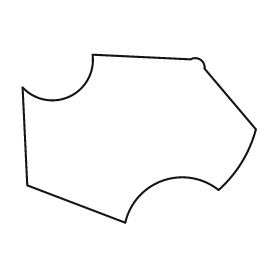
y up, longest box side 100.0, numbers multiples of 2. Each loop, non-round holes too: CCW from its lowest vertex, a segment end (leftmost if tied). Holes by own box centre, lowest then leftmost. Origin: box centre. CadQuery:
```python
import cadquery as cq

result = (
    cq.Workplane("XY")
    .moveTo(-6.0, -36.0)
    .threePointArc((10.0, -18.0), (34.0, -22.0))
    .threePointArc((44.0, -10.0), (50.0, 4.0))
    .lineTo(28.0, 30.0)
    .threePointArc((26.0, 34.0), (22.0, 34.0))
    .lineTo(-20.0, 36.0)
    .threePointArc((-30.0, 18.0), (-50.0, 22.0))
    .lineTo(-48.0, -20.0)
    .close()
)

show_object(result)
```